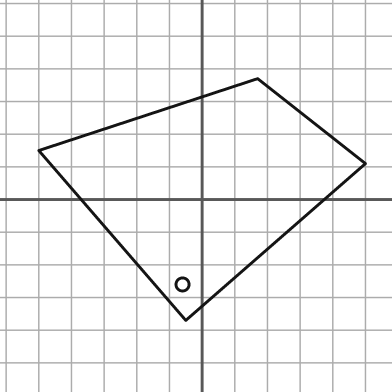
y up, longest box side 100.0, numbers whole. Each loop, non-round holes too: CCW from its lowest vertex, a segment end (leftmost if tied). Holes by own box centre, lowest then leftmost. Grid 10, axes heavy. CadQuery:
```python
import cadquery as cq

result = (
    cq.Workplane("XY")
    .moveTo(-5.0, -37.0)
    .lineTo(50.0, 11.0)
    .lineTo(17.0, 37.0)
    .lineTo(-50.0, 15.0)
    .close()
    .moveTo(-6.0, -26.0)
    .circle(2.0)
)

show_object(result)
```